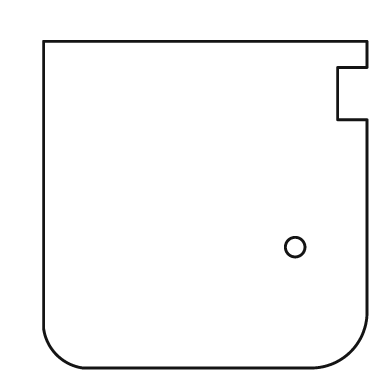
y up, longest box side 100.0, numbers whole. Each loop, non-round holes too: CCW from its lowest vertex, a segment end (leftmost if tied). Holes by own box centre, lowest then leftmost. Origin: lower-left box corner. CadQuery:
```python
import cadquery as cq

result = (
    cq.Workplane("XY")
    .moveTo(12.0, 0.0)
    .lineTo(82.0, 0.0)
    .threePointArc((94.0, 5.0), (99.0, 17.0))
    .lineTo(99.0, 76.0)
    .lineTo(90.0, 76.0)
    .lineTo(90.0, 92.0)
    .lineTo(99.0, 92.0)
    .lineTo(99.0, 100.0)
    .lineTo(0.0, 100.0)
    .lineTo(0.0, 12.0)
    .threePointArc((4.0, 4.0), (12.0, 0.0))
    .close()
    .moveTo(77.0, 37.0)
    .circle(3.0)
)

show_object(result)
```